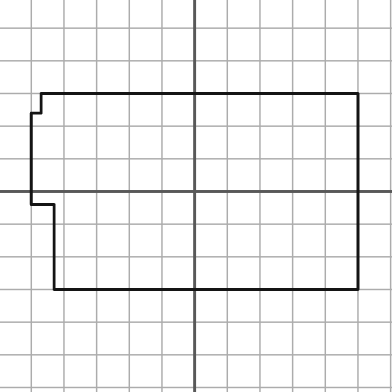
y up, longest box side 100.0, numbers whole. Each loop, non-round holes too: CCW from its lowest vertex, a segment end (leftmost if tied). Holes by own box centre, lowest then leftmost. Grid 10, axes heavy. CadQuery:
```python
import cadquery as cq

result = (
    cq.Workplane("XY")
    .moveTo(-43.0, -30.0)
    .lineTo(50.0, -30.0)
    .lineTo(50.0, 30.0)
    .lineTo(-47.0, 30.0)
    .lineTo(-47.0, 24.0)
    .lineTo(-50.0, 24.0)
    .lineTo(-50.0, -4.0)
    .lineTo(-43.0, -4.0)
    .close()
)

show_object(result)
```